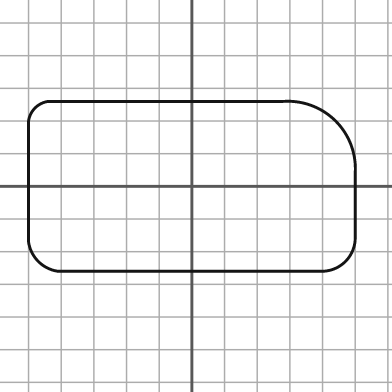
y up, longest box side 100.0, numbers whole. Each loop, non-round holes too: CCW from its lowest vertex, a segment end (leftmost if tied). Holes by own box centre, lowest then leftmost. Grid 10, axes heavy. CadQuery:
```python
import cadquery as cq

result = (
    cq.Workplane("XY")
    .moveTo(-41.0, -26.0)
    .lineTo(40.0, -26.0)
    .threePointArc((47.0, -23.0), (50.0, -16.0))
    .lineTo(50.0, 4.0)
    .threePointArc((44.0, 20.0), (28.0, 26.0))
    .lineTo(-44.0, 26.0)
    .threePointArc((-48.0, 24.0), (-50.0, 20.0))
    .lineTo(-50.0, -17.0)
    .threePointArc((-47.0, -23.0), (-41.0, -26.0))
    .close()
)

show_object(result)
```